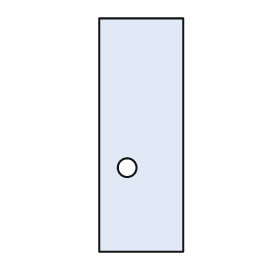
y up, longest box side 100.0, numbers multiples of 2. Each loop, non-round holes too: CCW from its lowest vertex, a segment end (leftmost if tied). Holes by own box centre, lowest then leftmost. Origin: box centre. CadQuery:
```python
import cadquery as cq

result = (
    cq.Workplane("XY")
    .moveTo(-18.0, -50.0)
    .lineTo(18.0, -50.0)
    .lineTo(18.0, 50.0)
    .lineTo(-18.0, 50.0)
    .close()
    .moveTo(-6.0, -14.0)
    .circle(4.0)
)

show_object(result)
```